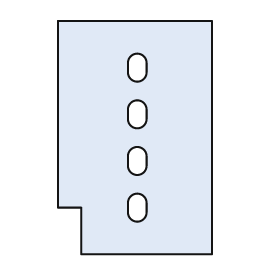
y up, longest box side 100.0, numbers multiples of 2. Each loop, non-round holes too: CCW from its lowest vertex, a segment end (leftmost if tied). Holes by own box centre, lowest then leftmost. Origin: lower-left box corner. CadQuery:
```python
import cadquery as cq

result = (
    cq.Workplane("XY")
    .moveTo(10.0, 0.0)
    .lineTo(66.0, 0.0)
    .lineTo(66.0, 100.0)
    .lineTo(0.0, 100.0)
    .lineTo(0.0, 20.0)
    .lineTo(10.0, 20.0)
    .close()
    .moveTo(30.0, 18.0)
    .threePointArc((34.0, 14.0), (38.0, 18.0))
    .lineTo(38.0, 22.0)
    .threePointArc((34.0, 26.0), (30.0, 22.0))
    .close()
    .moveTo(30.0, 38.0)
    .threePointArc((34.0, 34.0), (38.0, 38.0))
    .lineTo(38.0, 42.0)
    .threePointArc((34.0, 46.0), (30.0, 42.0))
    .close()
    .moveTo(30.0, 58.0)
    .threePointArc((34.0, 54.0), (38.0, 58.0))
    .lineTo(38.0, 62.0)
    .threePointArc((34.0, 66.0), (30.0, 62.0))
    .close()
    .moveTo(30.0, 78.0)
    .threePointArc((34.0, 74.0), (38.0, 78.0))
    .lineTo(38.0, 82.0)
    .threePointArc((34.0, 86.0), (30.0, 82.0))
    .close()
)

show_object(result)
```